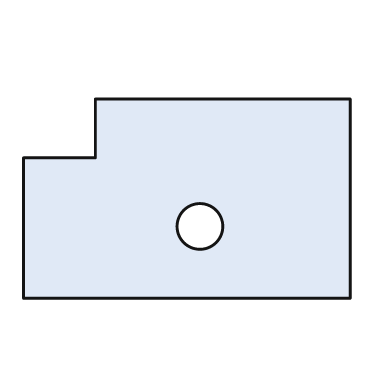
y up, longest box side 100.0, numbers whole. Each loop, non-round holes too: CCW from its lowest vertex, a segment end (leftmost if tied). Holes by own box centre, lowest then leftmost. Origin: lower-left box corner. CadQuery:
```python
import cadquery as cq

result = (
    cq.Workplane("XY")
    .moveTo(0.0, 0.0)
    .lineTo(100.0, 0.0)
    .lineTo(100.0, 61.0)
    .lineTo(22.0, 61.0)
    .lineTo(22.0, 43.0)
    .lineTo(0.0, 43.0)
    .close()
    .moveTo(54.0, 22.0)
    .circle(7.0)
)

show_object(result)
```